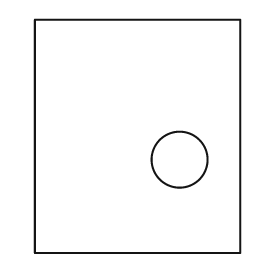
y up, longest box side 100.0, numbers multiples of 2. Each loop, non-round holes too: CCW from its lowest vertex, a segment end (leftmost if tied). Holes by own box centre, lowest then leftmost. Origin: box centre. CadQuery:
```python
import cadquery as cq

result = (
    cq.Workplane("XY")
    .moveTo(-44.0, -50.0)
    .lineTo(44.0, -50.0)
    .lineTo(44.0, 50.0)
    .lineTo(-44.0, 50.0)
    .close()
    .moveTo(18.0, -10.0)
    .circle(12.0)
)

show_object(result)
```